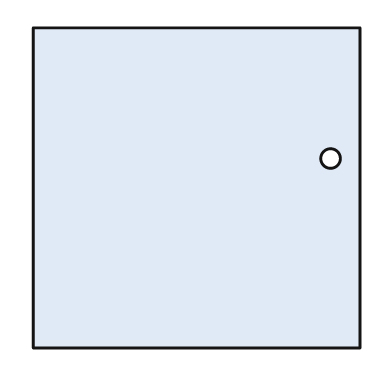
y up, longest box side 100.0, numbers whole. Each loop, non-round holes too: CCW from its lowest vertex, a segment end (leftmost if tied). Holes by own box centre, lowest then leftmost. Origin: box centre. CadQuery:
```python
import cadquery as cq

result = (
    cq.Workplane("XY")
    .moveTo(-50.0, -49.0)
    .lineTo(50.0, -49.0)
    .lineTo(50.0, 49.0)
    .lineTo(-50.0, 49.0)
    .close()
    .moveTo(41.0, 9.0)
    .circle(3.0)
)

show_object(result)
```